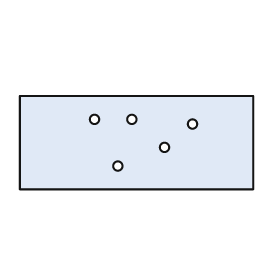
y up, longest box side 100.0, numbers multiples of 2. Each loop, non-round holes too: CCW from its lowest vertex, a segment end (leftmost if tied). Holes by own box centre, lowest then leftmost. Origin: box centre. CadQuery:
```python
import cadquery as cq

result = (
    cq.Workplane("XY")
    .moveTo(-50.0, -20.0)
    .lineTo(50.0, -20.0)
    .lineTo(50.0, 20.0)
    .lineTo(-50.0, 20.0)
    .close()
    .moveTo(-8.0, -10.0)
    .circle(2.0)
    .moveTo(12.0, -2.0)
    .circle(2.0)
    .moveTo(24.0, 8.0)
    .circle(2.0)
    .moveTo(-18.0, 10.0)
    .circle(2.0)
    .moveTo(-2.0, 10.0)
    .circle(2.0)
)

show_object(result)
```